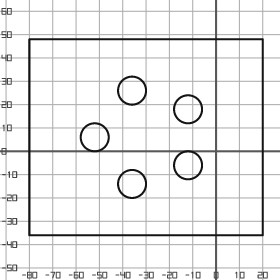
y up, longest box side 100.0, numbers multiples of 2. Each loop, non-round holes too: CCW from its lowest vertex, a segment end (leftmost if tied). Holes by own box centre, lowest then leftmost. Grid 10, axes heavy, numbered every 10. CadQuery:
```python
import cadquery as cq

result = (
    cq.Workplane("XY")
    .moveTo(-80.0, -36.0)
    .lineTo(20.0, -36.0)
    .lineTo(20.0, 48.0)
    .lineTo(-80.0, 48.0)
    .close()
    .moveTo(-36.0, -14.0)
    .circle(6.0)
    .moveTo(-12.0, -6.0)
    .circle(6.0)
    .moveTo(-52.0, 6.0)
    .circle(6.0)
    .moveTo(-12.0, 18.0)
    .circle(6.0)
    .moveTo(-36.0, 26.0)
    .circle(6.0)
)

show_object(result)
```